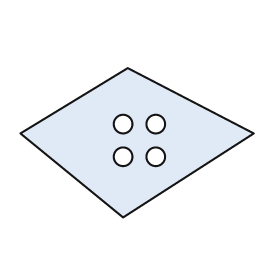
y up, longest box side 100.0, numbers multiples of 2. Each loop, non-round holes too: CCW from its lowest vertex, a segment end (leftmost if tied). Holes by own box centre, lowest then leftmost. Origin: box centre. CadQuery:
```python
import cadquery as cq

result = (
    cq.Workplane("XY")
    .moveTo(-6.0, -32.0)
    .lineTo(50.0, 4.0)
    .lineTo(-4.0, 32.0)
    .lineTo(-50.0, 4.0)
    .close()
    .moveTo(-6.0, -6.0)
    .circle(4.0)
    .moveTo(8.0, -6.0)
    .circle(4.0)
    .moveTo(-6.0, 8.0)
    .circle(4.0)
    .moveTo(8.0, 8.0)
    .circle(4.0)
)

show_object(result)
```